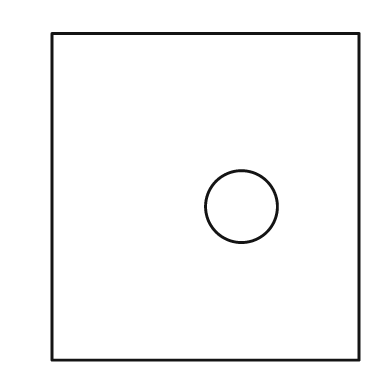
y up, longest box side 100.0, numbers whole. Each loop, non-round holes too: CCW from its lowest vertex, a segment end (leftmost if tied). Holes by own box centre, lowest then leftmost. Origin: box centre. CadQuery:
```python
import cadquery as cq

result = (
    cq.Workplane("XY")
    .moveTo(-47.0, -50.0)
    .lineTo(47.0, -50.0)
    .lineTo(47.0, 50.0)
    .lineTo(-47.0, 50.0)
    .close()
    .moveTo(11.0, -3.0)
    .circle(11.0)
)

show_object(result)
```